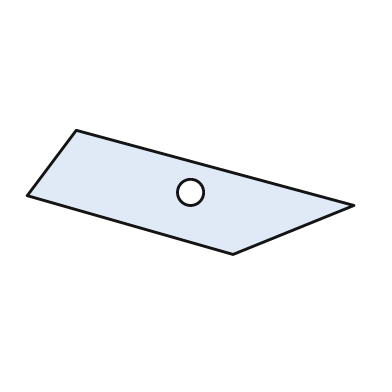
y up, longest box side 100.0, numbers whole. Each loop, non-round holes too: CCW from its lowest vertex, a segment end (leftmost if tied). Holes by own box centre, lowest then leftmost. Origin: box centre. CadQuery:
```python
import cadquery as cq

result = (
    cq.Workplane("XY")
    .moveTo(13.0, -19.0)
    .lineTo(50.0, -4.0)
    .lineTo(-35.0, 19.0)
    .lineTo(-50.0, -1.0)
    .close()
    .moveTo(0.0, 0.0)
    .circle(4.0)
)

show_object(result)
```